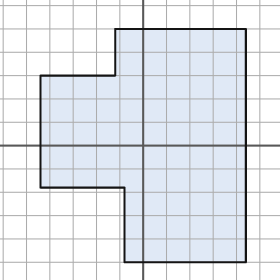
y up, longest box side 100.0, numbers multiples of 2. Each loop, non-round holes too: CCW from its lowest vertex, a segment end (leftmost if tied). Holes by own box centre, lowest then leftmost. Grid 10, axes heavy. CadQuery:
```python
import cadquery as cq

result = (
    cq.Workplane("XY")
    .moveTo(-8.0, -50.0)
    .lineTo(44.0, -50.0)
    .lineTo(44.0, 50.0)
    .lineTo(-12.0, 50.0)
    .lineTo(-12.0, 30.0)
    .lineTo(-44.0, 30.0)
    .lineTo(-44.0, -18.0)
    .lineTo(-8.0, -18.0)
    .close()
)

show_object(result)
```